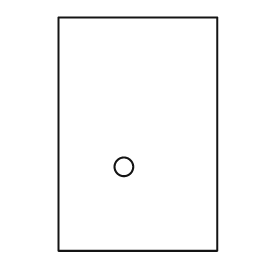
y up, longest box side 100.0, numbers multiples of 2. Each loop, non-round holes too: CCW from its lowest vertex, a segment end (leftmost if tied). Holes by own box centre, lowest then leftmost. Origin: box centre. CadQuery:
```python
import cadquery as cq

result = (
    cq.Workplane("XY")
    .moveTo(-34.0, -50.0)
    .lineTo(34.0, -50.0)
    .lineTo(34.0, 50.0)
    .lineTo(-34.0, 50.0)
    .close()
    .moveTo(-6.0, -14.0)
    .circle(4.0)
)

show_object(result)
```